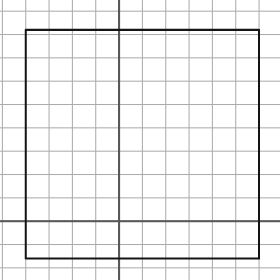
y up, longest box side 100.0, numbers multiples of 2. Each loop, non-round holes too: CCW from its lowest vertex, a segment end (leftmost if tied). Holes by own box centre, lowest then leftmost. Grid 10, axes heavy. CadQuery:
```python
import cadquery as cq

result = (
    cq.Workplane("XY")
    .moveTo(-40.0, -16.0)
    .lineTo(60.0, -16.0)
    .lineTo(60.0, 82.0)
    .lineTo(-40.0, 82.0)
    .close()
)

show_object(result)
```